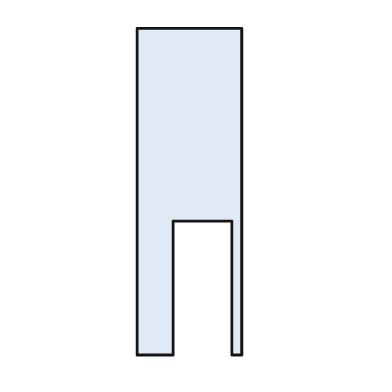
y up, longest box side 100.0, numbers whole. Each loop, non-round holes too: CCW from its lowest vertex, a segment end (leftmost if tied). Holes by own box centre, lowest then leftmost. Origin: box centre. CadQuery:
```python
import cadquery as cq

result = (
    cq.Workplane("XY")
    .moveTo(-16.0, -50.0)
    .lineTo(-5.0, -50.0)
    .lineTo(-5.0, -9.0)
    .lineTo(13.0, -9.0)
    .lineTo(13.0, -50.0)
    .lineTo(16.0, -50.0)
    .lineTo(16.0, 50.0)
    .lineTo(-16.0, 50.0)
    .close()
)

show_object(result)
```